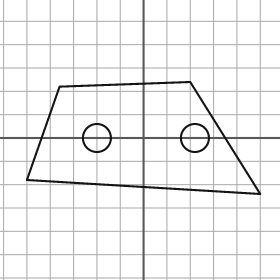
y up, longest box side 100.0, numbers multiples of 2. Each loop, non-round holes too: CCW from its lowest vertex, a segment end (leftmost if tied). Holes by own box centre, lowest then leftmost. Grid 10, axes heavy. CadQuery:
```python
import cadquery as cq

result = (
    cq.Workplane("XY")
    .moveTo(50.0, -24.0)
    .lineTo(20.0, 24.0)
    .lineTo(-36.0, 22.0)
    .lineTo(-50.0, -18.0)
    .close()
    .moveTo(-20.0, 0.0)
    .circle(6.0)
    .moveTo(22.0, 0.0)
    .circle(6.0)
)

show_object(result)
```